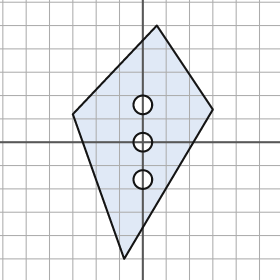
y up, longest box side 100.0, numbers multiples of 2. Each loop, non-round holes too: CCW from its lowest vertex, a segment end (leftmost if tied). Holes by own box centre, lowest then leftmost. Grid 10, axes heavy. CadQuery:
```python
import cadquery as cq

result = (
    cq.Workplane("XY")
    .moveTo(-8.0, -50.0)
    .lineTo(30.0, 14.0)
    .lineTo(6.0, 50.0)
    .lineTo(-30.0, 12.0)
    .close()
    .moveTo(0.0, -16.0)
    .circle(4.0)
    .moveTo(0.0, 0.0)
    .circle(4.0)
    .moveTo(0.0, 16.0)
    .circle(4.0)
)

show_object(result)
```